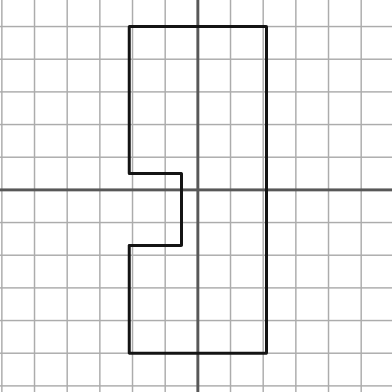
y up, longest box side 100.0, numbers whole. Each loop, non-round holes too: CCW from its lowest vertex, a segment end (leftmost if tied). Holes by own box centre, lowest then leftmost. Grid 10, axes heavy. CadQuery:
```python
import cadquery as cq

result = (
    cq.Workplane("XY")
    .moveTo(-21.0, -50.0)
    .lineTo(21.0, -50.0)
    .lineTo(21.0, 50.0)
    .lineTo(-21.0, 50.0)
    .lineTo(-21.0, 5.0)
    .lineTo(-5.0, 5.0)
    .lineTo(-5.0, -17.0)
    .lineTo(-21.0, -17.0)
    .close()
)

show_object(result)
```